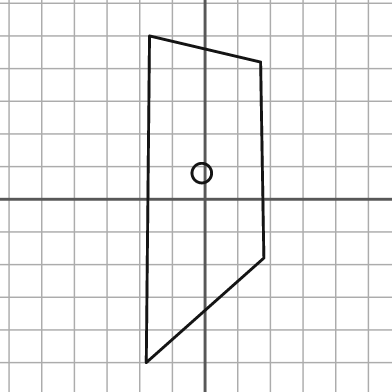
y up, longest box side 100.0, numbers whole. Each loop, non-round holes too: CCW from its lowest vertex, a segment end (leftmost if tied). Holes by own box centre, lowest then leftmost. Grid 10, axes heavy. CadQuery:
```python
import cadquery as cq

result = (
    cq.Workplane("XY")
    .moveTo(-18.0, -50.0)
    .lineTo(18.0, -18.0)
    .lineTo(17.0, 42.0)
    .lineTo(-17.0, 50.0)
    .close()
    .moveTo(-1.0, 8.0)
    .circle(3.0)
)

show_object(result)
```